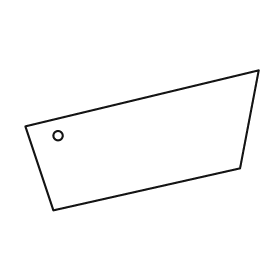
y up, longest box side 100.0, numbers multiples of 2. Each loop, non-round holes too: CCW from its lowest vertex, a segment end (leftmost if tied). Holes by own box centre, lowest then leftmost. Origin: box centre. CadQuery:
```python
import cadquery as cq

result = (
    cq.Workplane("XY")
    .moveTo(-38.0, -30.0)
    .lineTo(42.0, -12.0)
    .lineTo(50.0, 30.0)
    .lineTo(-50.0, 6.0)
    .close()
    .moveTo(-36.0, 2.0)
    .circle(2.0)
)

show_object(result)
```